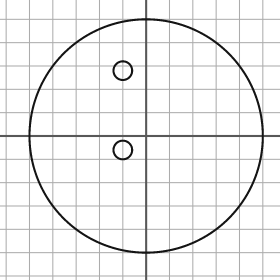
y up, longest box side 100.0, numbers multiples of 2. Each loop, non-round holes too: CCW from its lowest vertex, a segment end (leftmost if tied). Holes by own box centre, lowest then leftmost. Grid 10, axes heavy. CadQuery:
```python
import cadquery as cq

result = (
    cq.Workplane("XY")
    .moveTo(0.0, 0.0)
    .circle(50.0)
    .moveTo(-10.0, -6.0)
    .circle(4.0)
    .moveTo(-10.0, 28.0)
    .circle(4.0)
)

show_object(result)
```